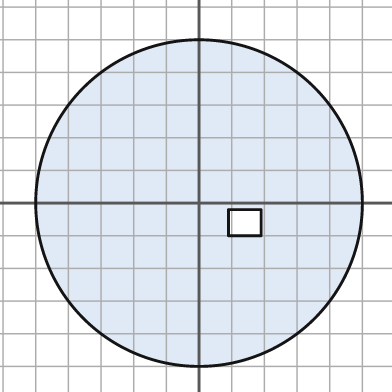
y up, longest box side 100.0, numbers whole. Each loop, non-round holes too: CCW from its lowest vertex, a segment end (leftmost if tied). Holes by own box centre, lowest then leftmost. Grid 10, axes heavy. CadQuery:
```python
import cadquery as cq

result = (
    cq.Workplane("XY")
    .moveTo(0.0, 0.0)
    .circle(50.0)
    .moveTo(9.0, -10.0)
    .lineTo(19.0, -10.0)
    .lineTo(19.0, -2.0)
    .lineTo(9.0, -2.0)
    .close()
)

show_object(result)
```